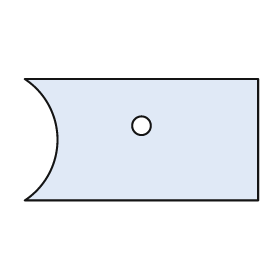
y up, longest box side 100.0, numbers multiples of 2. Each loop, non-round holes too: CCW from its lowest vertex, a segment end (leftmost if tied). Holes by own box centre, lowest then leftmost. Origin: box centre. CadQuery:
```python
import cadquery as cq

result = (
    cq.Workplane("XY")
    .moveTo(-50.0, -26.0)
    .lineTo(50.0, -26.0)
    .lineTo(50.0, 26.0)
    .lineTo(-50.0, 26.0)
    .threePointArc((-36.0, 0.0), (-50.0, -26.0))
    .close()
    .moveTo(0.0, 6.0)
    .circle(4.0)
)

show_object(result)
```